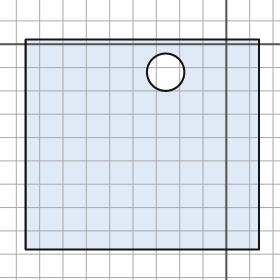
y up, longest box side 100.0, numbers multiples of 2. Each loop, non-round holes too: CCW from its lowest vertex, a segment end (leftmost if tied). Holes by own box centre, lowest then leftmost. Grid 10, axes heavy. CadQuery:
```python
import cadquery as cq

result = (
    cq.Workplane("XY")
    .moveTo(-86.0, -88.0)
    .lineTo(14.0, -88.0)
    .lineTo(14.0, 2.0)
    .lineTo(-86.0, 2.0)
    .close()
    .moveTo(-26.0, -12.0)
    .circle(8.0)
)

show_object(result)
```